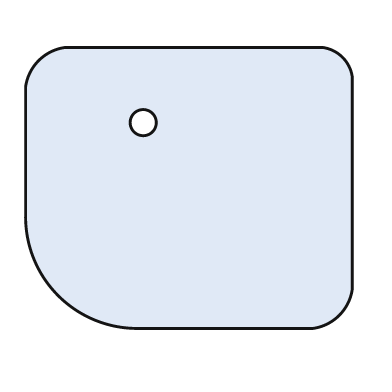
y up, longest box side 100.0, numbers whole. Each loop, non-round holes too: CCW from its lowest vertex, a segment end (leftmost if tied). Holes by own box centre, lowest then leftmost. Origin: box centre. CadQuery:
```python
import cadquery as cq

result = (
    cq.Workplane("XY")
    .moveTo(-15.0, -43.0)
    .lineTo(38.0, -43.0)
    .threePointArc((46.0, -39.0), (50.0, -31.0))
    .lineTo(50.0, 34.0)
    .threePointArc((47.0, 40.0), (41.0, 43.0))
    .lineTo(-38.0, 43.0)
    .threePointArc((-46.0, 39.0), (-50.0, 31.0))
    .lineTo(-50.0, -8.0)
    .threePointArc((-40.0, -33.0), (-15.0, -43.0))
    .close()
    .moveTo(-14.0, 20.0)
    .circle(4.0)
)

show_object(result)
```